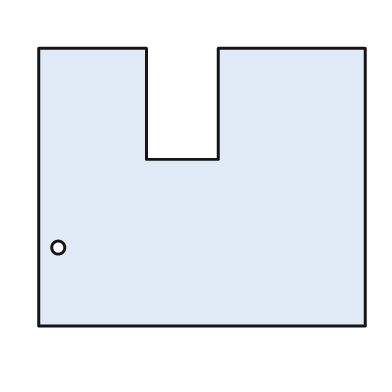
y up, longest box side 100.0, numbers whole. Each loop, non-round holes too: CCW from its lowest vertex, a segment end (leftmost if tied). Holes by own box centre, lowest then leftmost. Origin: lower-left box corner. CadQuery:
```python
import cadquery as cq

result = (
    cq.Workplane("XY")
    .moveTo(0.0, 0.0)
    .lineTo(100.0, 0.0)
    .lineTo(100.0, 85.0)
    .lineTo(55.0, 85.0)
    .lineTo(55.0, 51.0)
    .lineTo(33.0, 51.0)
    .lineTo(33.0, 85.0)
    .lineTo(0.0, 85.0)
    .close()
    .moveTo(6.0, 24.0)
    .circle(2.0)
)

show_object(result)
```